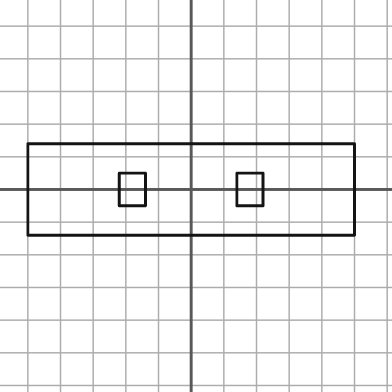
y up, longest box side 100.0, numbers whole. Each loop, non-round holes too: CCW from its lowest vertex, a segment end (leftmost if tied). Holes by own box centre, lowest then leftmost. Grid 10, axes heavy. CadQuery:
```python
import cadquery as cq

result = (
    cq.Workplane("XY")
    .moveTo(-50.0, -14.0)
    .lineTo(50.0, -14.0)
    .lineTo(50.0, 14.0)
    .lineTo(-50.0, 14.0)
    .close()
    .moveTo(-22.0, -5.0)
    .lineTo(-14.0, -5.0)
    .lineTo(-14.0, 5.0)
    .lineTo(-22.0, 5.0)
    .close()
    .moveTo(14.0, -5.0)
    .lineTo(22.0, -5.0)
    .lineTo(22.0, 5.0)
    .lineTo(14.0, 5.0)
    .close()
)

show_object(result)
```